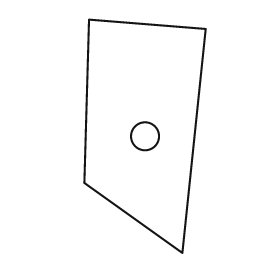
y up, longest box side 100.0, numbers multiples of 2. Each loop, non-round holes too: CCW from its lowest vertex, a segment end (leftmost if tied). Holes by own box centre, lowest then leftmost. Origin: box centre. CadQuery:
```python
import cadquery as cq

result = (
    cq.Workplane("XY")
    .moveTo(16.0, -50.0)
    .lineTo(26.0, 46.0)
    .lineTo(-24.0, 50.0)
    .lineTo(-26.0, -20.0)
    .close()
    .moveTo(0.0, 0.0)
    .circle(6.0)
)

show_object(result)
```